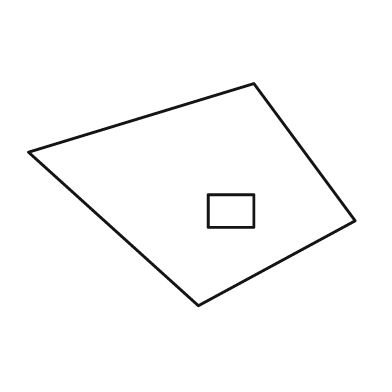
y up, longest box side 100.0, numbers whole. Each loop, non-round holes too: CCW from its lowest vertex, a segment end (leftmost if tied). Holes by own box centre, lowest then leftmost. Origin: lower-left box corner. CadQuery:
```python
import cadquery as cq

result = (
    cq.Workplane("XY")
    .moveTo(52.0, 0.0)
    .lineTo(100.0, 26.0)
    .lineTo(69.0, 68.0)
    .lineTo(0.0, 47.0)
    .close()
    .moveTo(55.0, 24.0)
    .lineTo(69.0, 24.0)
    .lineTo(69.0, 34.0)
    .lineTo(55.0, 34.0)
    .close()
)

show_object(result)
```